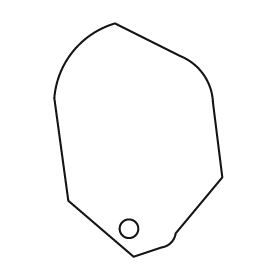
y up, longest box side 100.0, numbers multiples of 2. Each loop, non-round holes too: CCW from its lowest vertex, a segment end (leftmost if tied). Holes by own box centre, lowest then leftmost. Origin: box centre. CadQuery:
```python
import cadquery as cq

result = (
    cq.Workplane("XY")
    .moveTo(-2.0, -50.0)
    .lineTo(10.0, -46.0)
    .threePointArc((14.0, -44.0), (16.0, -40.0))
    .lineTo(36.0, -16.0)
    .lineTo(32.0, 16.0)
    .threePointArc((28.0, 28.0), (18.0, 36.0))
    .lineTo(-10.0, 50.0)
    .threePointArc((-28.0, 38.0), (-36.0, 18.0))
    .lineTo(-30.0, -26.0)
    .close()
    .moveTo(-4.0, -38.0)
    .circle(4.0)
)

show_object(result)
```